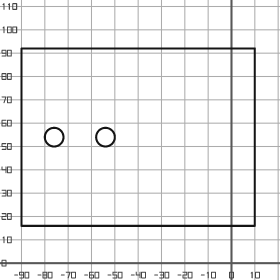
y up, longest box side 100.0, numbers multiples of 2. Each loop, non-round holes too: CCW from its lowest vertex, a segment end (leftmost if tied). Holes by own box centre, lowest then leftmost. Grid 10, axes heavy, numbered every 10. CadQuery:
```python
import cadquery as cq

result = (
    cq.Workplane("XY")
    .moveTo(-90.0, 16.0)
    .lineTo(10.0, 16.0)
    .lineTo(10.0, 92.0)
    .lineTo(-90.0, 92.0)
    .close()
    .moveTo(-76.0, 54.0)
    .circle(4.0)
    .moveTo(-54.0, 54.0)
    .circle(4.0)
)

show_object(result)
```